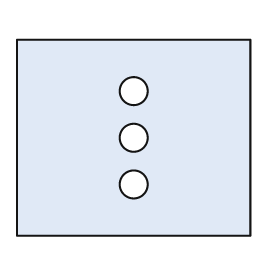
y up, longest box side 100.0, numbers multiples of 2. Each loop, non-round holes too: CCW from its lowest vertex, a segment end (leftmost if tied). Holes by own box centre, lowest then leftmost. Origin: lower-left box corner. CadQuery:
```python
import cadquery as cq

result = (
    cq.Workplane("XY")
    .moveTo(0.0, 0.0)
    .lineTo(100.0, 0.0)
    .lineTo(100.0, 84.0)
    .lineTo(0.0, 84.0)
    .close()
    .moveTo(50.0, 22.0)
    .circle(6.0)
    .moveTo(50.0, 42.0)
    .circle(6.0)
    .moveTo(50.0, 62.0)
    .circle(6.0)
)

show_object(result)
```